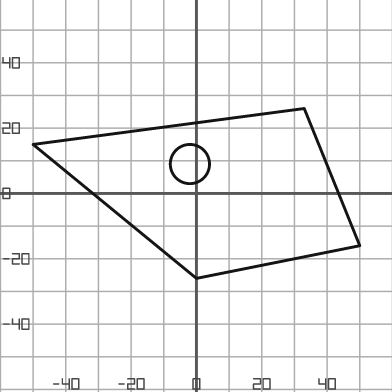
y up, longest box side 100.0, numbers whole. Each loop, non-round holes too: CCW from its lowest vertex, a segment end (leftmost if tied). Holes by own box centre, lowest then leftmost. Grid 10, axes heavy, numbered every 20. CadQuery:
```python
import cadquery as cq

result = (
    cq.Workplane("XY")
    .moveTo(0.0, -26.0)
    .lineTo(50.0, -16.0)
    .lineTo(33.0, 26.0)
    .lineTo(-50.0, 15.0)
    .close()
    .moveTo(-2.0, 9.0)
    .circle(6.0)
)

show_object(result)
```